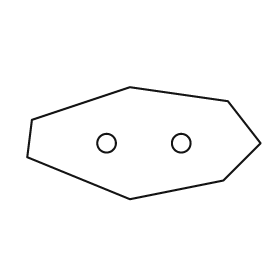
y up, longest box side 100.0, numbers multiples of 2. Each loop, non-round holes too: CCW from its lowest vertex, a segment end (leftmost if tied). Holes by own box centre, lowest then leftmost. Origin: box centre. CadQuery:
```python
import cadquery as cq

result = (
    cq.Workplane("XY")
    .moveTo(-6.0, -24.0)
    .lineTo(34.0, -16.0)
    .lineTo(50.0, 0.0)
    .lineTo(36.0, 18.0)
    .lineTo(-6.0, 24.0)
    .lineTo(-48.0, 10.0)
    .lineTo(-50.0, -6.0)
    .close()
    .moveTo(-16.0, 0.0)
    .circle(4.0)
    .moveTo(16.0, 0.0)
    .circle(4.0)
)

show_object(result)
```